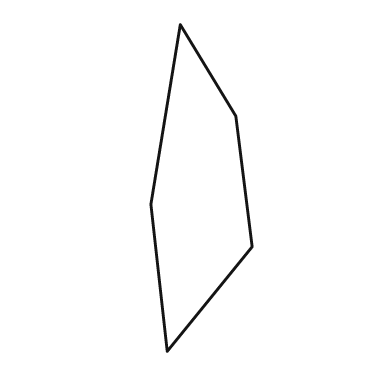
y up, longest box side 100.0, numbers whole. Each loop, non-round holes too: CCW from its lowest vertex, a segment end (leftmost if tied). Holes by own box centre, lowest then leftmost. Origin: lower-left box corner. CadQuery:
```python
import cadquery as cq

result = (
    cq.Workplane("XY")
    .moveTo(5.0, 0.0)
    .lineTo(31.0, 32.0)
    .lineTo(26.0, 72.0)
    .lineTo(9.0, 100.0)
    .lineTo(0.0, 45.0)
    .close()
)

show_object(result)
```